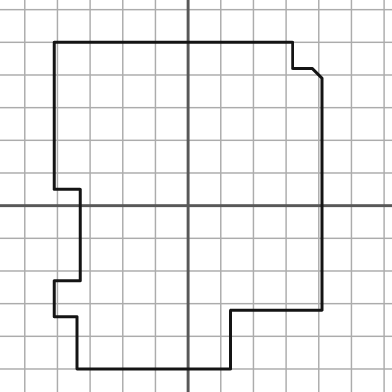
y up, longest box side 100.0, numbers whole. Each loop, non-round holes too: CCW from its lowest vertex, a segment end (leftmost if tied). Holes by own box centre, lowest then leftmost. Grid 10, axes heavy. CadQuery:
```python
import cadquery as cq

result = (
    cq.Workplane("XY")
    .moveTo(-34.0, -50.0)
    .lineTo(13.0, -50.0)
    .lineTo(13.0, -32.0)
    .lineTo(41.0, -32.0)
    .lineTo(41.0, 39.0)
    .lineTo(38.0, 42.0)
    .lineTo(32.0, 42.0)
    .lineTo(32.0, 50.0)
    .lineTo(-41.0, 50.0)
    .lineTo(-41.0, 5.0)
    .lineTo(-33.0, 5.0)
    .lineTo(-33.0, -23.0)
    .lineTo(-41.0, -23.0)
    .lineTo(-41.0, -34.0)
    .lineTo(-34.0, -34.0)
    .close()
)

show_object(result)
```